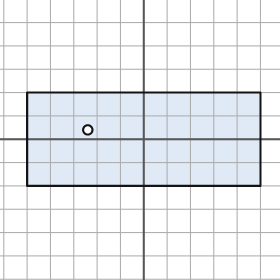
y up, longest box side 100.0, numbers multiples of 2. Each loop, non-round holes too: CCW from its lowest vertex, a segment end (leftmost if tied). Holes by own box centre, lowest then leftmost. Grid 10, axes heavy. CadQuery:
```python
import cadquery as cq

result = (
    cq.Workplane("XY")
    .moveTo(-50.0, -20.0)
    .lineTo(50.0, -20.0)
    .lineTo(50.0, 20.0)
    .lineTo(-50.0, 20.0)
    .close()
    .moveTo(-24.0, 4.0)
    .circle(2.0)
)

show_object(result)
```